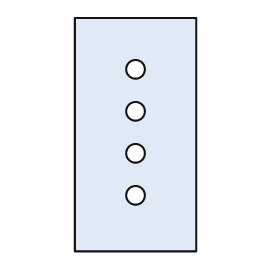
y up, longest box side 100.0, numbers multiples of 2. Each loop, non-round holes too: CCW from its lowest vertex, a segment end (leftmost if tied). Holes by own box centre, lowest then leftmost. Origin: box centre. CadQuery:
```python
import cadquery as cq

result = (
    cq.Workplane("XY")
    .moveTo(-26.0, -50.0)
    .lineTo(26.0, -50.0)
    .lineTo(26.0, 50.0)
    .lineTo(-26.0, 50.0)
    .close()
    .moveTo(0.0, -26.0)
    .circle(4.0)
    .moveTo(0.0, -8.0)
    .circle(4.0)
    .moveTo(0.0, 10.0)
    .circle(4.0)
    .moveTo(0.0, 28.0)
    .circle(4.0)
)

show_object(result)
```